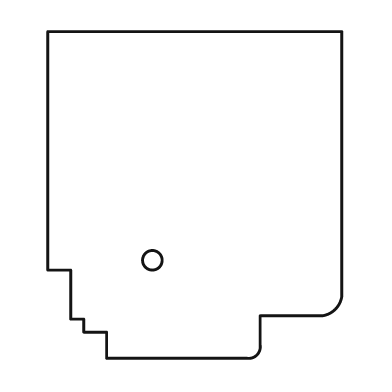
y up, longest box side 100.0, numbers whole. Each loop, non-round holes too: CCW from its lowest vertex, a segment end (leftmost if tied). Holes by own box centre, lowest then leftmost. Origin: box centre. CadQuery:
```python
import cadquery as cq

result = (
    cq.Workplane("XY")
    .moveTo(-27.0, -50.0)
    .lineTo(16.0, -50.0)
    .threePointArc((19.0, -49.0), (20.0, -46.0))
    .lineTo(20.0, -37.0)
    .lineTo(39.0, -37.0)
    .threePointArc((43.0, -35.0), (45.0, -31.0))
    .lineTo(45.0, 50.0)
    .lineTo(-45.0, 50.0)
    .lineTo(-45.0, -23.0)
    .lineTo(-38.0, -23.0)
    .lineTo(-38.0, -38.0)
    .lineTo(-34.0, -38.0)
    .lineTo(-34.0, -42.0)
    .lineTo(-27.0, -42.0)
    .close()
    .moveTo(-13.0, -20.0)
    .circle(3.0)
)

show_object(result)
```